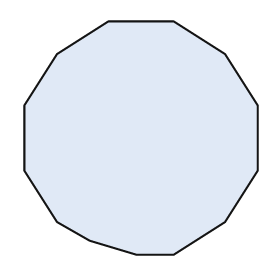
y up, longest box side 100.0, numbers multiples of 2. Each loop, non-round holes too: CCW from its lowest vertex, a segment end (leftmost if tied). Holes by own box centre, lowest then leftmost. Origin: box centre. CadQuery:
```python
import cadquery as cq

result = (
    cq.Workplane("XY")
    .moveTo(-2.0, -50.0)
    .lineTo(14.0, -50.0)
    .lineTo(36.0, -36.0)
    .lineTo(50.0, -14.0)
    .lineTo(50.0, 14.0)
    .lineTo(36.0, 36.0)
    .lineTo(14.0, 50.0)
    .lineTo(-14.0, 50.0)
    .lineTo(-36.0, 36.0)
    .lineTo(-50.0, 14.0)
    .lineTo(-50.0, -14.0)
    .lineTo(-36.0, -36.0)
    .lineTo(-22.0, -44.0)
    .close()
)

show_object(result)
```